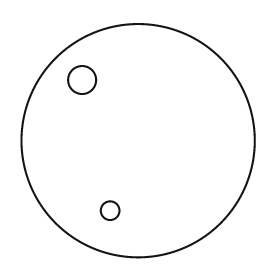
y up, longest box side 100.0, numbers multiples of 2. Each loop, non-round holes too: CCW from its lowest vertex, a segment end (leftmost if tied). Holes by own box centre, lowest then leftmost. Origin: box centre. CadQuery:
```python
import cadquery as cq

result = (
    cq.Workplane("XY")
    .moveTo(0.0, 0.0)
    .circle(50.0)
    .moveTo(-12.0, -30.0)
    .circle(4.0)
    .moveTo(-24.0, 26.0)
    .circle(6.0)
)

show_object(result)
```